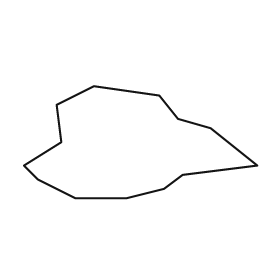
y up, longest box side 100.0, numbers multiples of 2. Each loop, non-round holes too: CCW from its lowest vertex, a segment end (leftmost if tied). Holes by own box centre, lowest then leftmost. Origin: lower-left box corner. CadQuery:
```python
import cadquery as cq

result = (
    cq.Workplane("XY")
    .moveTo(22.0, 0.0)
    .lineTo(44.0, 0.0)
    .lineTo(60.0, 4.0)
    .lineTo(68.0, 10.0)
    .lineTo(100.0, 14.0)
    .lineTo(80.0, 30.0)
    .lineTo(66.0, 34.0)
    .lineTo(58.0, 44.0)
    .lineTo(30.0, 48.0)
    .lineTo(14.0, 40.0)
    .lineTo(16.0, 24.0)
    .lineTo(0.0, 14.0)
    .lineTo(6.0, 8.0)
    .close()
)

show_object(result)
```